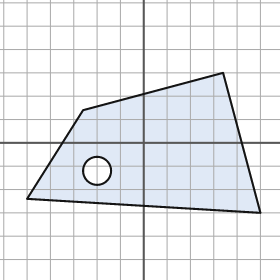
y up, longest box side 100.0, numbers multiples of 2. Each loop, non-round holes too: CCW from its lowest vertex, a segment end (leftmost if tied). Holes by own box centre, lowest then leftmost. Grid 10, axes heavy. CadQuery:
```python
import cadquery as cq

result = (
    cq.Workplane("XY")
    .moveTo(50.0, -30.0)
    .lineTo(34.0, 30.0)
    .lineTo(-26.0, 14.0)
    .lineTo(-50.0, -24.0)
    .close()
    .moveTo(-20.0, -12.0)
    .circle(6.0)
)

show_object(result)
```